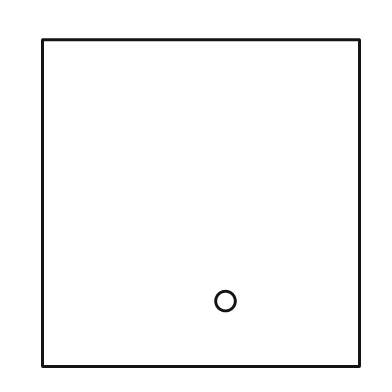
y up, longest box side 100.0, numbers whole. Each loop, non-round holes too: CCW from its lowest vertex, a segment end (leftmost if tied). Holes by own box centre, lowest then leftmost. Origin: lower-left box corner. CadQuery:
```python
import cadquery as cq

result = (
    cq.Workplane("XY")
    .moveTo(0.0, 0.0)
    .lineTo(97.0, 0.0)
    .lineTo(97.0, 100.0)
    .lineTo(0.0, 100.0)
    .close()
    .moveTo(56.0, 20.0)
    .circle(3.0)
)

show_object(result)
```